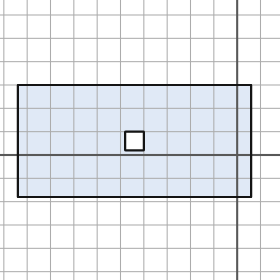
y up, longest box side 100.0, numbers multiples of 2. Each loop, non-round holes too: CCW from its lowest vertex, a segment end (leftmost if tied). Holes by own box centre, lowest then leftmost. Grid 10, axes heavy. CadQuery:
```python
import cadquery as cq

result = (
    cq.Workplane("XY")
    .moveTo(-94.0, -18.0)
    .lineTo(6.0, -18.0)
    .lineTo(6.0, 30.0)
    .lineTo(-94.0, 30.0)
    .close()
    .moveTo(-48.0, 2.0)
    .lineTo(-40.0, 2.0)
    .lineTo(-40.0, 10.0)
    .lineTo(-48.0, 10.0)
    .close()
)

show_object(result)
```